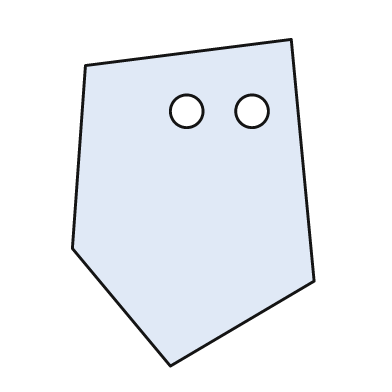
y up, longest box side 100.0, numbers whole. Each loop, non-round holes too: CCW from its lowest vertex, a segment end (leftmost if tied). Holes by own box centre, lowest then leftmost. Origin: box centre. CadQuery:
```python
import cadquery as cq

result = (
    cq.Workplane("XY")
    .moveTo(-7.0, -50.0)
    .lineTo(37.0, -24.0)
    .lineTo(30.0, 50.0)
    .lineTo(-33.0, 42.0)
    .lineTo(-37.0, -14.0)
    .close()
    .moveTo(-2.0, 28.0)
    .circle(5.0)
    .moveTo(18.0, 28.0)
    .circle(5.0)
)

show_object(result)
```